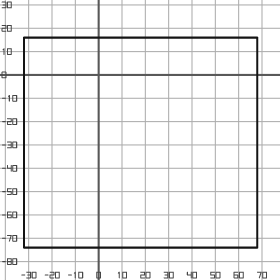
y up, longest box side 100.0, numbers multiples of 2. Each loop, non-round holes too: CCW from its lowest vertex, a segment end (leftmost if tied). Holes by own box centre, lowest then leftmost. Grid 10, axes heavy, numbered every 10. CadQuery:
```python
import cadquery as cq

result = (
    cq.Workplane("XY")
    .moveTo(-32.0, -74.0)
    .lineTo(68.0, -74.0)
    .lineTo(68.0, 16.0)
    .lineTo(-32.0, 16.0)
    .close()
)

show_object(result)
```